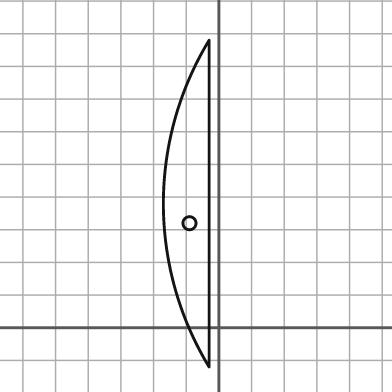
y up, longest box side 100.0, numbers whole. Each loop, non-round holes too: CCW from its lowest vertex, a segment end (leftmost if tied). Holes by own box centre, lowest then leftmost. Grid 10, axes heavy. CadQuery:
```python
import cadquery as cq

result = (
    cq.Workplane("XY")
    .moveTo(-3.0, -12.0)
    .lineTo(-3.0, 88.0)
    .threePointArc((-17.0, 38.0), (-3.0, -12.0))
    .close()
    .moveTo(-9.0, 32.0)
    .circle(2.0)
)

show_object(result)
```